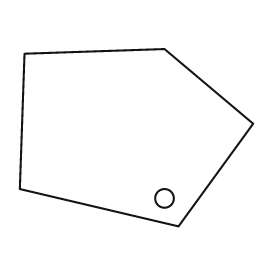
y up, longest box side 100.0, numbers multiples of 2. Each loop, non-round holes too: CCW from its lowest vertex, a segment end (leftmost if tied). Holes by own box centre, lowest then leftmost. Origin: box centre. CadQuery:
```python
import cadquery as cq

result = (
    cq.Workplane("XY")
    .moveTo(18.0, -38.0)
    .lineTo(50.0, 6.0)
    .lineTo(12.0, 38.0)
    .lineTo(-48.0, 36.0)
    .lineTo(-50.0, -22.0)
    .close()
    .moveTo(12.0, -26.0)
    .circle(4.0)
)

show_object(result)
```